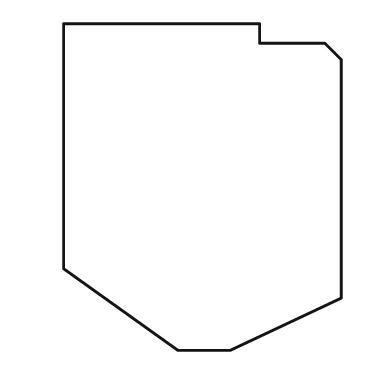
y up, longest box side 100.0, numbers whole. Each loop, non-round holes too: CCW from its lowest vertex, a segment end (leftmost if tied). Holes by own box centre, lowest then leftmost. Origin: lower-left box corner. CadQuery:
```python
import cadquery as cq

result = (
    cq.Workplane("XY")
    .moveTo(35.0, 0.0)
    .lineTo(51.0, 0.0)
    .lineTo(85.0, 16.0)
    .lineTo(85.0, 89.0)
    .lineTo(80.0, 94.0)
    .lineTo(60.0, 94.0)
    .lineTo(60.0, 100.0)
    .lineTo(0.0, 100.0)
    .lineTo(0.0, 25.0)
    .close()
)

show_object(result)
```